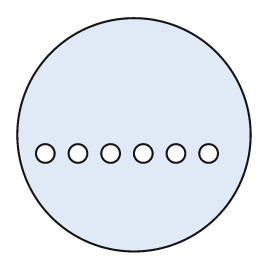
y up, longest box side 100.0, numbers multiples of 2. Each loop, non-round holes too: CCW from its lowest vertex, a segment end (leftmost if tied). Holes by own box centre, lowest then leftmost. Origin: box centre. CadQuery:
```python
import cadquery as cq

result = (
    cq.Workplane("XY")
    .moveTo(0.0, 0.0)
    .circle(50.0)
    .moveTo(-38.0, -8.0)
    .circle(4.0)
    .moveTo(-24.0, -8.0)
    .circle(4.0)
    .moveTo(-10.0, -8.0)
    .circle(4.0)
    .moveTo(4.0, -8.0)
    .circle(4.0)
    .moveTo(18.0, -8.0)
    .circle(4.0)
    .moveTo(32.0, -8.0)
    .circle(4.0)
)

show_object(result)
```